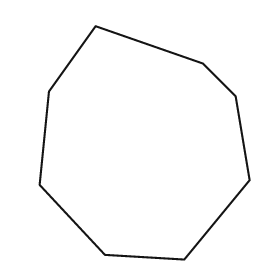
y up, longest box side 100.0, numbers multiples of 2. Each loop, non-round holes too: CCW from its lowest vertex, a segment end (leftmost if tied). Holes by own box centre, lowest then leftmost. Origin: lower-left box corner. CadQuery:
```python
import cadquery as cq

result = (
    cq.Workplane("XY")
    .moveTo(62.0, 0.0)
    .lineTo(90.0, 34.0)
    .lineTo(84.0, 70.0)
    .lineTo(70.0, 84.0)
    .lineTo(24.0, 100.0)
    .lineTo(4.0, 72.0)
    .lineTo(0.0, 32.0)
    .lineTo(28.0, 2.0)
    .close()
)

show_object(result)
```